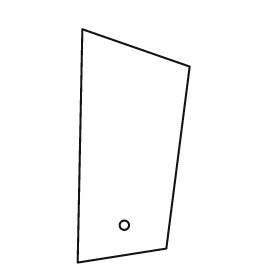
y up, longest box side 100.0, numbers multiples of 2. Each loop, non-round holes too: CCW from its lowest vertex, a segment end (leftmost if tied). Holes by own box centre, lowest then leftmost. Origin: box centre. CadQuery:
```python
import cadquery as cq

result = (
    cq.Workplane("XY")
    .moveTo(-24.0, -50.0)
    .lineTo(14.0, -44.0)
    .lineTo(24.0, 34.0)
    .lineTo(-22.0, 50.0)
    .close()
    .moveTo(-4.0, -34.0)
    .circle(2.0)
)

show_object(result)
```